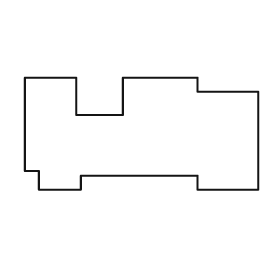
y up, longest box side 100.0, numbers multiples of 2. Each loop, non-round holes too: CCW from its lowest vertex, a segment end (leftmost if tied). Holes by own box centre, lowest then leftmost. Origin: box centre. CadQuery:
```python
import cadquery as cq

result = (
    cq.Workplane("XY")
    .moveTo(-44.0, -24.0)
    .lineTo(-26.0, -24.0)
    .lineTo(-26.0, -18.0)
    .lineTo(24.0, -18.0)
    .lineTo(24.0, -24.0)
    .lineTo(50.0, -24.0)
    .lineTo(50.0, 18.0)
    .lineTo(24.0, 18.0)
    .lineTo(24.0, 24.0)
    .lineTo(-8.0, 24.0)
    .lineTo(-8.0, 8.0)
    .lineTo(-28.0, 8.0)
    .lineTo(-28.0, 24.0)
    .lineTo(-50.0, 24.0)
    .lineTo(-50.0, -16.0)
    .lineTo(-44.0, -16.0)
    .close()
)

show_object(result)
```